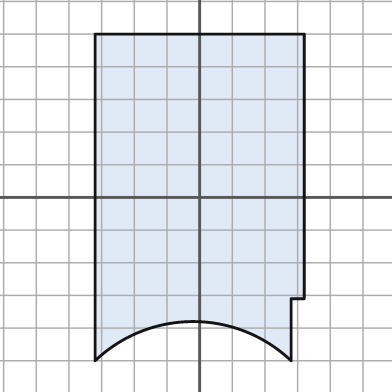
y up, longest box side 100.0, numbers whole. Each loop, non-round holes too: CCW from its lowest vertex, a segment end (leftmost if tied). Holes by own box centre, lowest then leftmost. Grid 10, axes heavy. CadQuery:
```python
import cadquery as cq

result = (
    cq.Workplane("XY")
    .moveTo(-32.0, -50.0)
    .threePointArc((-2.0, -38.0), (28.0, -50.0))
    .lineTo(28.0, -31.0)
    .lineTo(32.0, -31.0)
    .lineTo(32.0, 50.0)
    .lineTo(-32.0, 50.0)
    .close()
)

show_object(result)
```